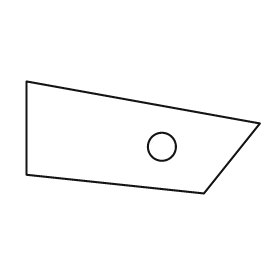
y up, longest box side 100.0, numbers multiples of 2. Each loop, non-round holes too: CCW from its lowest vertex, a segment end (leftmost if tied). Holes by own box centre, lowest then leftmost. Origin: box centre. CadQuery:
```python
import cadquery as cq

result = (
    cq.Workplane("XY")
    .moveTo(26.0, -24.0)
    .lineTo(50.0, 6.0)
    .lineTo(-50.0, 24.0)
    .lineTo(-50.0, -16.0)
    .close()
    .moveTo(8.0, -4.0)
    .circle(6.0)
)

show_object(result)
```